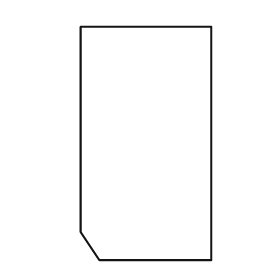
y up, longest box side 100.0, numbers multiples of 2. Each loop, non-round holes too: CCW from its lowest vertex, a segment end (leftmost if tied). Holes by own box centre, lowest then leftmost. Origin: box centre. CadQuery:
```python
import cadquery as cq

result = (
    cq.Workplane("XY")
    .moveTo(-20.0, -50.0)
    .lineTo(28.0, -50.0)
    .lineTo(28.0, 50.0)
    .lineTo(-28.0, 50.0)
    .lineTo(-28.0, -38.0)
    .close()
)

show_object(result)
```